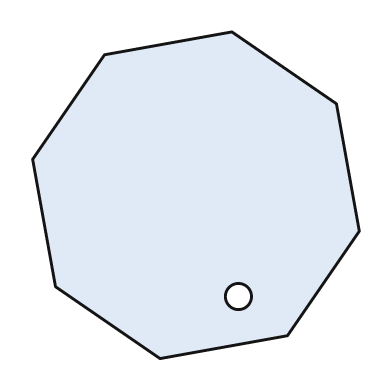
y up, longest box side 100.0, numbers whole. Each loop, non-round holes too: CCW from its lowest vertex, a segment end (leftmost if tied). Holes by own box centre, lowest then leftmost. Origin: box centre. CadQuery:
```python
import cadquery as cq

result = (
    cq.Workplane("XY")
    .moveTo(-11.0, -50.0)
    .lineTo(28.0, -43.0)
    .lineTo(50.0, -11.0)
    .lineTo(43.0, 28.0)
    .lineTo(11.0, 50.0)
    .lineTo(-28.0, 43.0)
    .lineTo(-50.0, 11.0)
    .lineTo(-43.0, -28.0)
    .close()
    .moveTo(13.0, -31.0)
    .circle(4.0)
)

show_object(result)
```